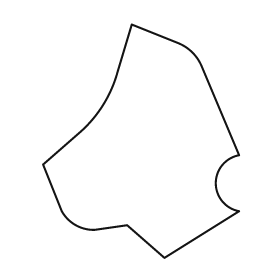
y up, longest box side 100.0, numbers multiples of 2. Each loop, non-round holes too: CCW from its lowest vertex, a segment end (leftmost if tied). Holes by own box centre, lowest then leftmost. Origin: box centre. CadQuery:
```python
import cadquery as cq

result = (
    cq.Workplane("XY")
    .moveTo(10.0, -50.0)
    .lineTo(42.0, -30.0)
    .threePointArc((32.0, -18.0), (42.0, -6.0))
    .lineTo(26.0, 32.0)
    .threePointArc((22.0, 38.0), (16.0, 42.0))
    .lineTo(-4.0, 50.0)
    .lineTo(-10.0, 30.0)
    .threePointArc((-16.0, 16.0), (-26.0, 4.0))
    .lineTo(-42.0, -10.0)
    .lineTo(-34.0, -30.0)
    .threePointArc((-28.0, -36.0), (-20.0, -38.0))
    .lineTo(-6.0, -36.0)
    .close()
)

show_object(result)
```